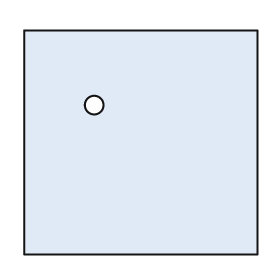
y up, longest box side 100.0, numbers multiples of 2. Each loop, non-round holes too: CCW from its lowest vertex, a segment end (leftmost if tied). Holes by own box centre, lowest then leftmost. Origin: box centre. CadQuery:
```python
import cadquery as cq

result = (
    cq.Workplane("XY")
    .moveTo(-50.0, -48.0)
    .lineTo(50.0, -48.0)
    .lineTo(50.0, 48.0)
    .lineTo(-50.0, 48.0)
    .close()
    .moveTo(-20.0, 16.0)
    .circle(4.0)
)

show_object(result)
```